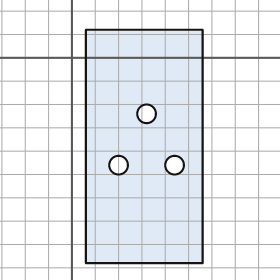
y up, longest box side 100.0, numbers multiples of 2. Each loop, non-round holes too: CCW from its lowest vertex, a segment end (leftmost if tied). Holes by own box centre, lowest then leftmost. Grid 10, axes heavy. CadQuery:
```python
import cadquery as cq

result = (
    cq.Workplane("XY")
    .moveTo(6.0, -88.0)
    .lineTo(56.0, -88.0)
    .lineTo(56.0, 12.0)
    .lineTo(6.0, 12.0)
    .close()
    .moveTo(20.0, -46.0)
    .circle(4.0)
    .moveTo(44.0, -46.0)
    .circle(4.0)
    .moveTo(32.0, -24.0)
    .circle(4.0)
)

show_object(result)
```